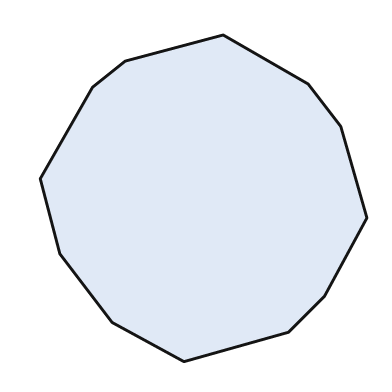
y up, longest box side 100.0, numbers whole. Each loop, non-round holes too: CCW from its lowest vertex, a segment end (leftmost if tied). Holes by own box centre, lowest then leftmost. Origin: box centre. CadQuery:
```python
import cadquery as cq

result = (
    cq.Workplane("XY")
    .moveTo(-6.0, -50.0)
    .lineTo(26.0, -41.0)
    .lineTo(37.0, -30.0)
    .lineTo(50.0, -6.0)
    .lineTo(42.0, 22.0)
    .lineTo(32.0, 35.0)
    .lineTo(6.0, 50.0)
    .lineTo(-24.0, 42.0)
    .lineTo(-34.0, 34.0)
    .lineTo(-50.0, 6.0)
    .lineTo(-44.0, -17.0)
    .lineTo(-28.0, -38.0)
    .close()
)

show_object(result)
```